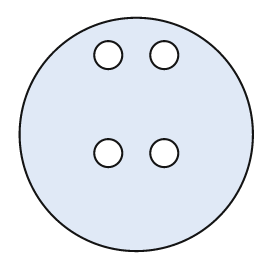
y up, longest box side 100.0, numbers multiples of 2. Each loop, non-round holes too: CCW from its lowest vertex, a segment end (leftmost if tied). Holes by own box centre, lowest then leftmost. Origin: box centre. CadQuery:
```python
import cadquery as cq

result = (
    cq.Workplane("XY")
    .moveTo(0.0, 0.0)
    .circle(50.0)
    .moveTo(-12.0, -8.0)
    .circle(6.0)
    .moveTo(12.0, -8.0)
    .circle(6.0)
    .moveTo(-12.0, 34.0)
    .circle(6.0)
    .moveTo(12.0, 34.0)
    .circle(6.0)
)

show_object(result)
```